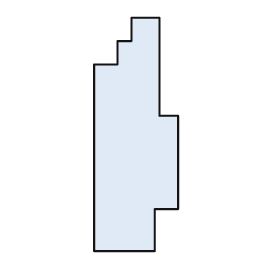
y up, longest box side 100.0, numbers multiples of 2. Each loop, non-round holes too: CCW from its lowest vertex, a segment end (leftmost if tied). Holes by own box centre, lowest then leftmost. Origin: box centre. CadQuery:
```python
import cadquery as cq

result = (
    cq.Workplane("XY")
    .moveTo(-18.0, -50.0)
    .lineTo(8.0, -50.0)
    .lineTo(8.0, -32.0)
    .lineTo(18.0, -32.0)
    .lineTo(18.0, 8.0)
    .lineTo(10.0, 8.0)
    .lineTo(10.0, 50.0)
    .lineTo(-2.0, 50.0)
    .lineTo(-2.0, 40.0)
    .lineTo(-8.0, 40.0)
    .lineTo(-8.0, 30.0)
    .lineTo(-18.0, 30.0)
    .close()
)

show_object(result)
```